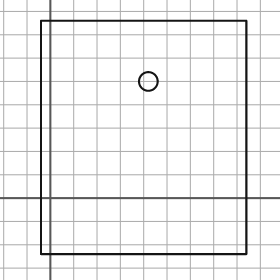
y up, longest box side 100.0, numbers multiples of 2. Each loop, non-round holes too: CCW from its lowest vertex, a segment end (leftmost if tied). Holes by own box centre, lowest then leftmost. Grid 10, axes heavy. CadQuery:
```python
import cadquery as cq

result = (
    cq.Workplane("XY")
    .moveTo(-4.0, -24.0)
    .lineTo(84.0, -24.0)
    .lineTo(84.0, 76.0)
    .lineTo(-4.0, 76.0)
    .close()
    .moveTo(42.0, 50.0)
    .circle(4.0)
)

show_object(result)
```